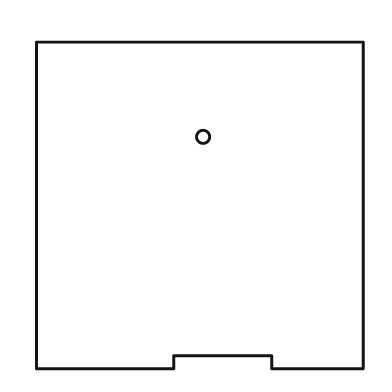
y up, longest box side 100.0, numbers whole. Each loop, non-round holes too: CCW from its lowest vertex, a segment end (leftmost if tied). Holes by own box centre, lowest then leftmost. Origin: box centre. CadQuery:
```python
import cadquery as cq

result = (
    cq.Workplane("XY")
    .moveTo(-50.0, -50.0)
    .lineTo(-8.0, -50.0)
    .lineTo(-8.0, -46.0)
    .lineTo(22.0, -46.0)
    .lineTo(22.0, -50.0)
    .lineTo(50.0, -50.0)
    .lineTo(50.0, 50.0)
    .lineTo(-50.0, 50.0)
    .close()
    .moveTo(1.0, 21.0)
    .circle(2.0)
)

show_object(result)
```